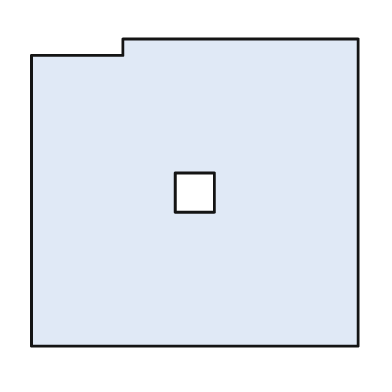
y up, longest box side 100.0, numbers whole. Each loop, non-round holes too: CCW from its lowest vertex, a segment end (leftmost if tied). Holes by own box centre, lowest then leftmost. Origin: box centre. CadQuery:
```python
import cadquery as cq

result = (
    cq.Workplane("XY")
    .moveTo(-50.0, -47.0)
    .lineTo(50.0, -47.0)
    .lineTo(50.0, 47.0)
    .lineTo(-22.0, 47.0)
    .lineTo(-22.0, 42.0)
    .lineTo(-50.0, 42.0)
    .close()
    .moveTo(-6.0, -6.0)
    .lineTo(6.0, -6.0)
    .lineTo(6.0, 6.0)
    .lineTo(-6.0, 6.0)
    .close()
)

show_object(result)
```